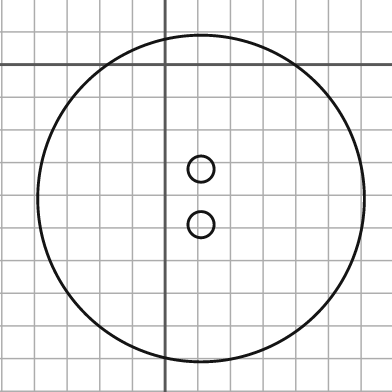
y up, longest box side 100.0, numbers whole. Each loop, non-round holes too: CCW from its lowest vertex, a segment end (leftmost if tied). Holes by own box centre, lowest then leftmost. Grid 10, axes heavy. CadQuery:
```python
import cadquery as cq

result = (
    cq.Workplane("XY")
    .moveTo(11.0, -41.0)
    .circle(50.0)
    .moveTo(11.0, -49.0)
    .circle(4.0)
    .moveTo(11.0, -32.0)
    .circle(4.0)
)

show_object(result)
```